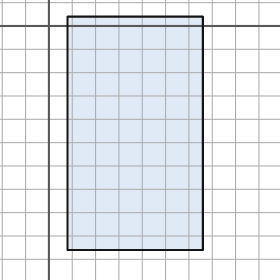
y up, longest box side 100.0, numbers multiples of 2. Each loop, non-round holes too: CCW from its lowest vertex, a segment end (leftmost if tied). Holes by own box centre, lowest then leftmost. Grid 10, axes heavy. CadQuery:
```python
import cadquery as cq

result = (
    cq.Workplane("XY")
    .moveTo(8.0, -96.0)
    .lineTo(66.0, -96.0)
    .lineTo(66.0, 4.0)
    .lineTo(8.0, 4.0)
    .close()
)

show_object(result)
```